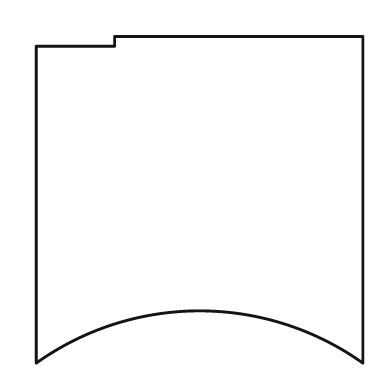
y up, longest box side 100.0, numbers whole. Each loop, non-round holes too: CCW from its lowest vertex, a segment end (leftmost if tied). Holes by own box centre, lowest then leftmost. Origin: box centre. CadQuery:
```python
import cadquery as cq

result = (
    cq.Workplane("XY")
    .moveTo(-50.0, -50.0)
    .threePointArc((0.0, -34.0), (50.0, -50.0))
    .lineTo(50.0, 50.0)
    .lineTo(-26.0, 50.0)
    .lineTo(-26.0, 47.0)
    .lineTo(-50.0, 47.0)
    .close()
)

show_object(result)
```